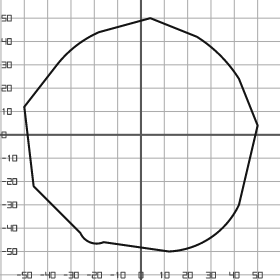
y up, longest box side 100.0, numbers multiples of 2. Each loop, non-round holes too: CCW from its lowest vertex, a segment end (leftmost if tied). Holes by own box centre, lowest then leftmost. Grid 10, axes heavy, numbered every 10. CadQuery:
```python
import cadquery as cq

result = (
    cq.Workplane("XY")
    .moveTo(12.0, -50.0)
    .threePointArc((30.0, -44.0), (42.0, -30.0))
    .lineTo(50.0, 4.0)
    .lineTo(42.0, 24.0)
    .threePointArc((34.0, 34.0), (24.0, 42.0))
    .lineTo(4.0, 50.0)
    .lineTo(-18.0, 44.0)
    .threePointArc((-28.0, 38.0), (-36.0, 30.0))
    .lineTo(-50.0, 12.0)
    .lineTo(-46.0, -22.0)
    .lineTo(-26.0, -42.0)
    .threePointArc((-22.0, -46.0), (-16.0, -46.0))
    .close()
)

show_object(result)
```